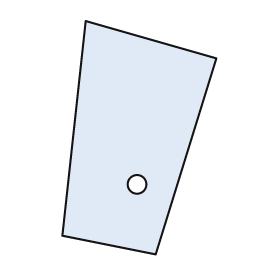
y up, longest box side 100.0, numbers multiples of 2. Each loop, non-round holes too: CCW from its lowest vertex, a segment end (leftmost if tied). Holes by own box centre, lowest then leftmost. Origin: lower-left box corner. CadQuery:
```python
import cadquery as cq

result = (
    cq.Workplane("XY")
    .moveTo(40.0, 0.0)
    .lineTo(66.0, 84.0)
    .lineTo(10.0, 100.0)
    .lineTo(0.0, 8.0)
    .close()
    .moveTo(32.0, 30.0)
    .circle(4.0)
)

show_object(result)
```